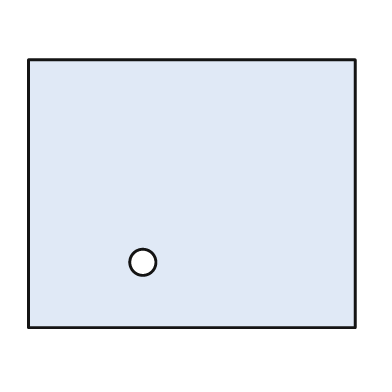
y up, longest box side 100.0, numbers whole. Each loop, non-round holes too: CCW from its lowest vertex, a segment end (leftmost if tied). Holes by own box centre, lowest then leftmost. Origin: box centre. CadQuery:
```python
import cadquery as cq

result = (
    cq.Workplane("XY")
    .moveTo(-50.0, -41.0)
    .lineTo(50.0, -41.0)
    .lineTo(50.0, 41.0)
    .lineTo(-50.0, 41.0)
    .close()
    .moveTo(-15.0, -21.0)
    .circle(4.0)
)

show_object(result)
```